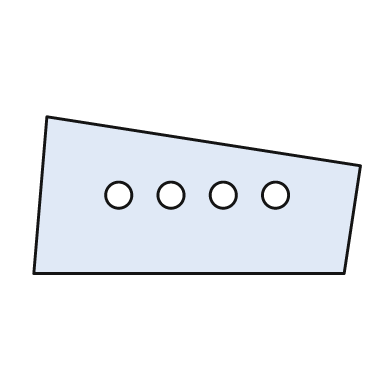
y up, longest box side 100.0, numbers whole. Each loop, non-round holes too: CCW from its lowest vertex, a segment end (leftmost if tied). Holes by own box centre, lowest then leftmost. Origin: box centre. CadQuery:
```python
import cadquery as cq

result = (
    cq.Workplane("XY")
    .moveTo(-50.0, -24.0)
    .lineTo(45.0, -24.0)
    .lineTo(50.0, 9.0)
    .lineTo(-46.0, 24.0)
    .close()
    .moveTo(-24.0, 0.0)
    .circle(4.0)
    .moveTo(-8.0, 0.0)
    .circle(4.0)
    .moveTo(8.0, 0.0)
    .circle(4.0)
    .moveTo(24.0, 0.0)
    .circle(4.0)
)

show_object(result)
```